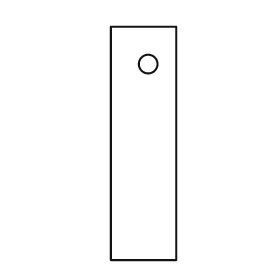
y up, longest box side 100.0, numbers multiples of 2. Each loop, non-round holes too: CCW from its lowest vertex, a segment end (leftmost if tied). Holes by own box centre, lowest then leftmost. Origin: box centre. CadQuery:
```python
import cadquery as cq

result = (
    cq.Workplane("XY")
    .moveTo(-14.0, -50.0)
    .lineTo(14.0, -50.0)
    .lineTo(14.0, 50.0)
    .lineTo(-14.0, 50.0)
    .close()
    .moveTo(2.0, 34.0)
    .circle(4.0)
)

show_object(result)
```